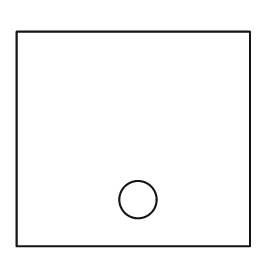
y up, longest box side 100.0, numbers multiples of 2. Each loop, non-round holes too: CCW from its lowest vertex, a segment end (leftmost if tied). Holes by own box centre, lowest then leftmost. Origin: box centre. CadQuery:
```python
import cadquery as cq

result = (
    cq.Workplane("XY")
    .moveTo(-50.0, -46.0)
    .lineTo(50.0, -46.0)
    .lineTo(50.0, 46.0)
    .lineTo(-50.0, 46.0)
    .close()
    .moveTo(2.0, -26.0)
    .circle(8.0)
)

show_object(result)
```